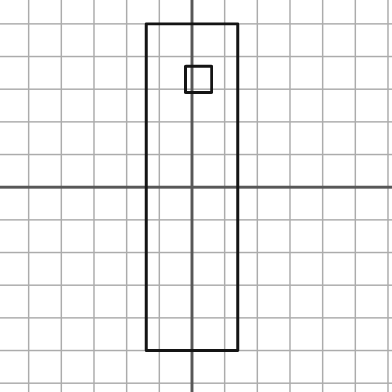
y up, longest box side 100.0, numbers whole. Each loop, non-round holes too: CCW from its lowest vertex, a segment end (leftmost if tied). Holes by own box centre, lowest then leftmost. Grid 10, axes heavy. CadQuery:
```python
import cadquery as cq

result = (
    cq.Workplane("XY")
    .moveTo(-14.0, -50.0)
    .lineTo(14.0, -50.0)
    .lineTo(14.0, 50.0)
    .lineTo(-14.0, 50.0)
    .close()
    .moveTo(-2.0, 29.0)
    .lineTo(6.0, 29.0)
    .lineTo(6.0, 37.0)
    .lineTo(-2.0, 37.0)
    .close()
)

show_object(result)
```